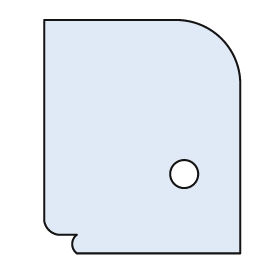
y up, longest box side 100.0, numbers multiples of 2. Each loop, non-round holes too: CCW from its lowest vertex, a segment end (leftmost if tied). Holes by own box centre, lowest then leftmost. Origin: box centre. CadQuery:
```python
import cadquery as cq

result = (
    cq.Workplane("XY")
    .moveTo(-28.0, -50.0)
    .lineTo(42.0, -50.0)
    .lineTo(42.0, 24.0)
    .threePointArc((34.0, 42.0), (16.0, 50.0))
    .lineTo(-42.0, 50.0)
    .lineTo(-42.0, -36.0)
    .threePointArc((-40.0, -40.0), (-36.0, -42.0))
    .lineTo(-28.0, -42.0)
    .threePointArc((-30.0, -46.0), (-28.0, -50.0))
    .close()
    .moveTo(18.0, -16.0)
    .circle(6.0)
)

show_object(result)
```